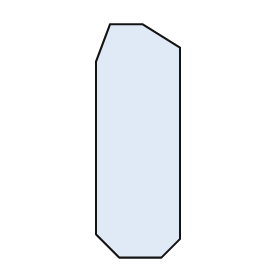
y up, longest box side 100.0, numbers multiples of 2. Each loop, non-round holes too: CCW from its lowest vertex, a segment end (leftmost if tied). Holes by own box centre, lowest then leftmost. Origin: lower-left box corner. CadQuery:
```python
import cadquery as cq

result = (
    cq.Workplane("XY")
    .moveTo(10.0, 0.0)
    .lineTo(28.0, 0.0)
    .lineTo(36.0, 8.0)
    .lineTo(36.0, 90.0)
    .lineTo(20.0, 100.0)
    .lineTo(6.0, 100.0)
    .lineTo(0.0, 84.0)
    .lineTo(0.0, 10.0)
    .close()
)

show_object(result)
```